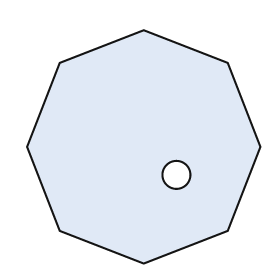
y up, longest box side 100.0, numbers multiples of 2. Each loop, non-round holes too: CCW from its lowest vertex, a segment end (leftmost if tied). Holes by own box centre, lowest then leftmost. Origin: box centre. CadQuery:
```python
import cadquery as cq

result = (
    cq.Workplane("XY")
    .moveTo(0.0, -50.0)
    .lineTo(36.0, -36.0)
    .lineTo(50.0, 0.0)
    .lineTo(36.0, 36.0)
    .lineTo(0.0, 50.0)
    .lineTo(-36.0, 36.0)
    .lineTo(-50.0, 0.0)
    .lineTo(-36.0, -36.0)
    .close()
    .moveTo(14.0, -12.0)
    .circle(6.0)
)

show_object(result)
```